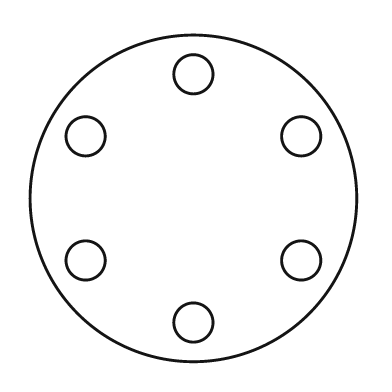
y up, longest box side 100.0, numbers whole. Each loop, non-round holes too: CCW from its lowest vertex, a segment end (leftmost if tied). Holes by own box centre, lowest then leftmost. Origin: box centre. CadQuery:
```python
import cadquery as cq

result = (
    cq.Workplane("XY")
    .moveTo(0.0, 0.0)
    .circle(50.0)
    .moveTo(0.0, -38.0)
    .circle(6.0)
    .moveTo(-33.0, -19.0)
    .circle(6.0)
    .moveTo(33.0, -19.0)
    .circle(6.0)
    .moveTo(-33.0, 19.0)
    .circle(6.0)
    .moveTo(33.0, 19.0)
    .circle(6.0)
    .moveTo(0.0, 38.0)
    .circle(6.0)
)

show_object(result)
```